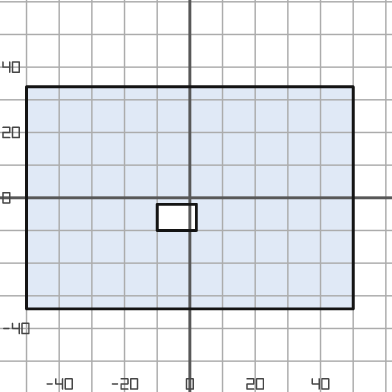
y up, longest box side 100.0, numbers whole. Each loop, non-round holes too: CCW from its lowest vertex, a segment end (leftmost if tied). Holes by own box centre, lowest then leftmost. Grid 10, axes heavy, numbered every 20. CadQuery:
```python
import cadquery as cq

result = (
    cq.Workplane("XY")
    .moveTo(-50.0, -34.0)
    .lineTo(50.0, -34.0)
    .lineTo(50.0, 34.0)
    .lineTo(-50.0, 34.0)
    .close()
    .moveTo(-10.0, -10.0)
    .lineTo(2.0, -10.0)
    .lineTo(2.0, -2.0)
    .lineTo(-10.0, -2.0)
    .close()
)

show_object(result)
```